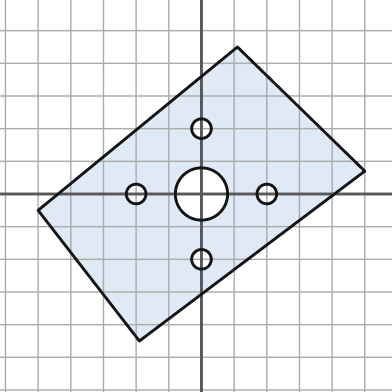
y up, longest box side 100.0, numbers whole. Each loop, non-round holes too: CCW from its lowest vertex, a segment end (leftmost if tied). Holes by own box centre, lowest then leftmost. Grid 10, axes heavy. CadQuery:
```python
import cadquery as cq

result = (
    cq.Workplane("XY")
    .moveTo(-19.0, -45.0)
    .lineTo(50.0, 7.0)
    .lineTo(11.0, 45.0)
    .lineTo(-50.0, -5.0)
    .close()
    .moveTo(0.0, -20.0)
    .circle(3.0)
    .moveTo(-20.0, 0.0)
    .circle(3.0)
    .moveTo(0.0, 0.0)
    .circle(8.0)
    .moveTo(20.0, 0.0)
    .circle(3.0)
    .moveTo(0.0, 20.0)
    .circle(3.0)
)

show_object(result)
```